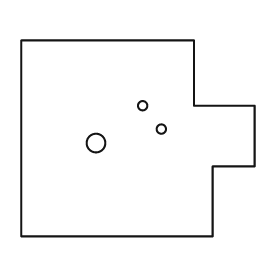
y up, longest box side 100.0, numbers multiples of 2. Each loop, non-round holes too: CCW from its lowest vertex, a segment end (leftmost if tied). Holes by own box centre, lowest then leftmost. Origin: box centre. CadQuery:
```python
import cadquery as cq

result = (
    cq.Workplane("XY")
    .moveTo(-50.0, -42.0)
    .lineTo(32.0, -42.0)
    .lineTo(32.0, -12.0)
    .lineTo(50.0, -12.0)
    .lineTo(50.0, 14.0)
    .lineTo(24.0, 14.0)
    .lineTo(24.0, 42.0)
    .lineTo(-50.0, 42.0)
    .close()
    .moveTo(-18.0, -2.0)
    .circle(4.0)
    .moveTo(10.0, 4.0)
    .circle(2.0)
    .moveTo(2.0, 14.0)
    .circle(2.0)
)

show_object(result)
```